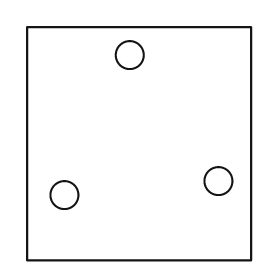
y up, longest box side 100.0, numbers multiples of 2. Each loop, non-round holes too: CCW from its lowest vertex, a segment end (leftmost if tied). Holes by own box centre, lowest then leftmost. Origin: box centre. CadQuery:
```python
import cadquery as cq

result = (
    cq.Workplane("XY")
    .moveTo(-48.0, -50.0)
    .lineTo(48.0, -50.0)
    .lineTo(48.0, 50.0)
    .lineTo(-48.0, 50.0)
    .close()
    .moveTo(-32.0, -22.0)
    .circle(6.0)
    .moveTo(34.0, -16.0)
    .circle(6.0)
    .moveTo(-4.0, 38.0)
    .circle(6.0)
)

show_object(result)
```